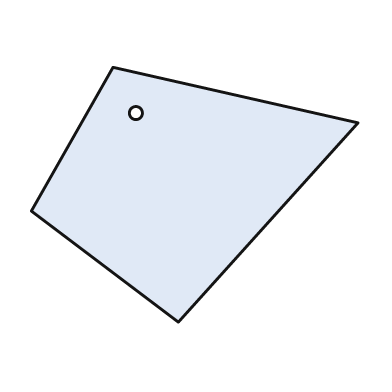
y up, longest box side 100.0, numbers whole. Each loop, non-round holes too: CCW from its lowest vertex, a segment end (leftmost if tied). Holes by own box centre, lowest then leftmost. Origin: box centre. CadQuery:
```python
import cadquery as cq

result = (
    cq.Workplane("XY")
    .moveTo(-5.0, -39.0)
    .lineTo(50.0, 22.0)
    .lineTo(-25.0, 39.0)
    .lineTo(-50.0, -5.0)
    .close()
    .moveTo(-18.0, 25.0)
    .circle(2.0)
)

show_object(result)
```